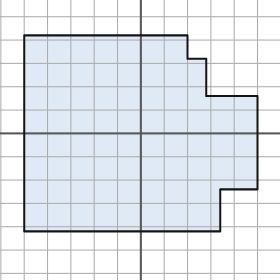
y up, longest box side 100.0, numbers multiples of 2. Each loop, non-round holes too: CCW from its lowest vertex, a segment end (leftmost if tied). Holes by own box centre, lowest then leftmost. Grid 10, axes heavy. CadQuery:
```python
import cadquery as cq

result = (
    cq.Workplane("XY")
    .moveTo(-50.0, -42.0)
    .lineTo(34.0, -42.0)
    .lineTo(34.0, -24.0)
    .lineTo(50.0, -24.0)
    .lineTo(50.0, 16.0)
    .lineTo(28.0, 16.0)
    .lineTo(28.0, 32.0)
    .lineTo(20.0, 32.0)
    .lineTo(20.0, 42.0)
    .lineTo(-50.0, 42.0)
    .close()
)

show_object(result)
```